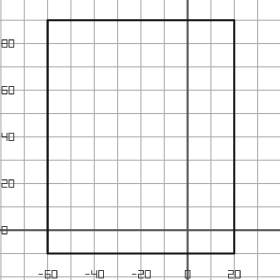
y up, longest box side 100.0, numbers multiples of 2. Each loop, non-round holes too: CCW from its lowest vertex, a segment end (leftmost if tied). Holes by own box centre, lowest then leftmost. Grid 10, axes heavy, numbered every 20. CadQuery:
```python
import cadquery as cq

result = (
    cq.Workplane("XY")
    .moveTo(-60.0, -10.0)
    .lineTo(20.0, -10.0)
    .lineTo(20.0, 90.0)
    .lineTo(-60.0, 90.0)
    .close()
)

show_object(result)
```